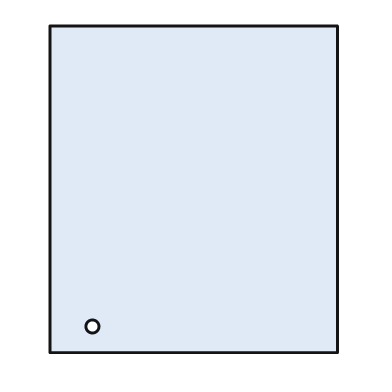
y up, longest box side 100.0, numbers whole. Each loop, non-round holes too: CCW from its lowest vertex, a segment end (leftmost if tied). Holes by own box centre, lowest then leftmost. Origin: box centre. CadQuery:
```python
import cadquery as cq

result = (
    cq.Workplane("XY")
    .moveTo(-44.0, -50.0)
    .lineTo(44.0, -50.0)
    .lineTo(44.0, 50.0)
    .lineTo(-44.0, 50.0)
    .close()
    .moveTo(-31.0, -42.0)
    .circle(2.0)
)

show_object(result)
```